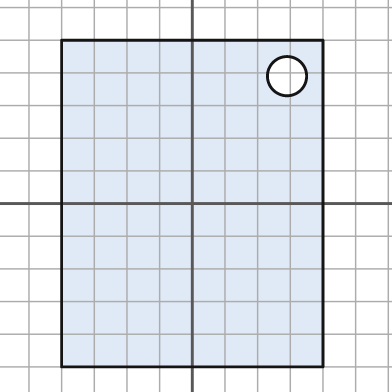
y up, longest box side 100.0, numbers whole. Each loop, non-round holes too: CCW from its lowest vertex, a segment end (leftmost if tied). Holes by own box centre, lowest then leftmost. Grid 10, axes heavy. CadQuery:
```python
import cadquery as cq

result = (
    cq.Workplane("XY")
    .moveTo(-40.0, -50.0)
    .lineTo(40.0, -50.0)
    .lineTo(40.0, 50.0)
    .lineTo(-40.0, 50.0)
    .close()
    .moveTo(29.0, 39.0)
    .circle(6.0)
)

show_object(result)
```